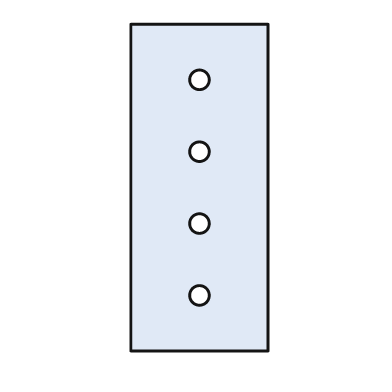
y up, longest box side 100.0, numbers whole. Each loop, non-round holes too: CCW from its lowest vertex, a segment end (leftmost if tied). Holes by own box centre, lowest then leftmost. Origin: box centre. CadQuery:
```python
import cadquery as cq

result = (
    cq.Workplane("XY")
    .moveTo(-21.0, -50.0)
    .lineTo(21.0, -50.0)
    .lineTo(21.0, 50.0)
    .lineTo(-21.0, 50.0)
    .close()
    .moveTo(0.0, -33.0)
    .circle(3.0)
    .moveTo(0.0, -11.0)
    .circle(3.0)
    .moveTo(0.0, 11.0)
    .circle(3.0)
    .moveTo(0.0, 33.0)
    .circle(3.0)
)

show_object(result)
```